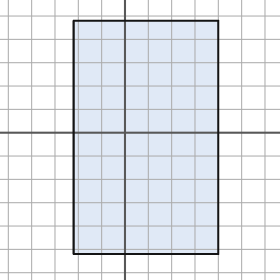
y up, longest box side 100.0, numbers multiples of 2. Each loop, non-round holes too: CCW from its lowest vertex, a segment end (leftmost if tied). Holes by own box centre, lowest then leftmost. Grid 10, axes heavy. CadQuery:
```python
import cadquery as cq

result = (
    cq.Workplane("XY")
    .moveTo(-22.0, -52.0)
    .lineTo(40.0, -52.0)
    .lineTo(40.0, 48.0)
    .lineTo(-22.0, 48.0)
    .close()
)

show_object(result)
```